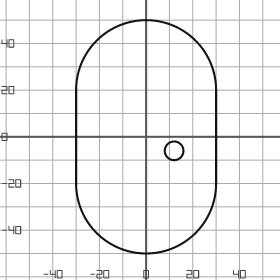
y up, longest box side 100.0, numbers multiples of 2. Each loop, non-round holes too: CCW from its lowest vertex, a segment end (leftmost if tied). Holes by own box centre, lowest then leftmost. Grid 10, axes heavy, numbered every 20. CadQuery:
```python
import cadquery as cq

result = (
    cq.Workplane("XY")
    .moveTo(-30.0, -20.0)
    .threePointArc((0.0, -50.0), (30.0, -20.0))
    .lineTo(30.0, 20.0)
    .threePointArc((0.0, 50.0), (-30.0, 20.0))
    .close()
    .moveTo(12.0, -6.0)
    .circle(4.0)
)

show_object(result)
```